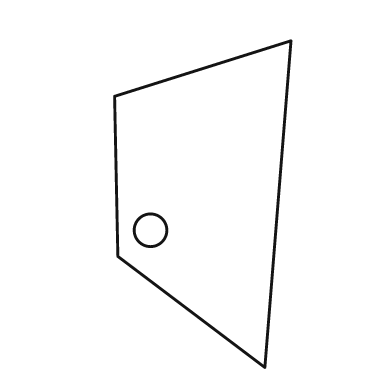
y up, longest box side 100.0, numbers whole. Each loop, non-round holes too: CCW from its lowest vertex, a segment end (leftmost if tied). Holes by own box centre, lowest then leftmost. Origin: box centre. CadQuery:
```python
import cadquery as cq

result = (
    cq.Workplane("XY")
    .moveTo(19.0, -50.0)
    .lineTo(27.0, 50.0)
    .lineTo(-27.0, 33.0)
    .lineTo(-26.0, -16.0)
    .close()
    .moveTo(-16.0, -8.0)
    .circle(5.0)
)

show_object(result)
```